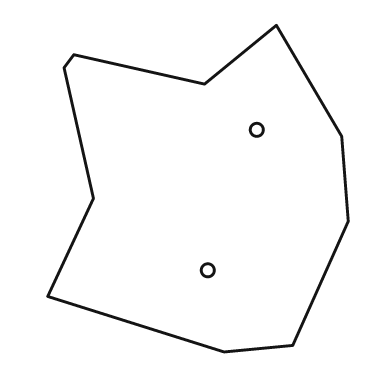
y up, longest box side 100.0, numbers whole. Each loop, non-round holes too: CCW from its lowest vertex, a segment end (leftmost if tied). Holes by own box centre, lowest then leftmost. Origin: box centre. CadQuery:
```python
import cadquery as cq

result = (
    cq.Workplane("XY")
    .moveTo(8.0, -50.0)
    .lineTo(29.0, -48.0)
    .lineTo(46.0, -10.0)
    .lineTo(44.0, 16.0)
    .lineTo(24.0, 50.0)
    .lineTo(2.0, 32.0)
    .lineTo(-38.0, 41.0)
    .lineTo(-41.0, 37.0)
    .lineTo(-32.0, -3.0)
    .lineTo(-46.0, -33.0)
    .close()
    .moveTo(3.0, -25.0)
    .circle(2.0)
    .moveTo(18.0, 18.0)
    .circle(2.0)
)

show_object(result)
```